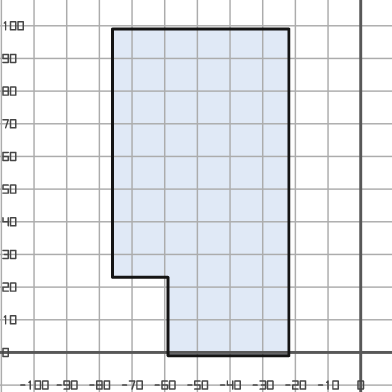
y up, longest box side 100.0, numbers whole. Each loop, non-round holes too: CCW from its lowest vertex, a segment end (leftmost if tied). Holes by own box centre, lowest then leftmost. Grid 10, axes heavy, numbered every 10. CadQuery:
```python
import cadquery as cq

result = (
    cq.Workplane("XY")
    .moveTo(-59.0, -1.0)
    .lineTo(-22.0, -1.0)
    .lineTo(-22.0, 99.0)
    .lineTo(-76.0, 99.0)
    .lineTo(-76.0, 23.0)
    .lineTo(-59.0, 23.0)
    .close()
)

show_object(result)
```